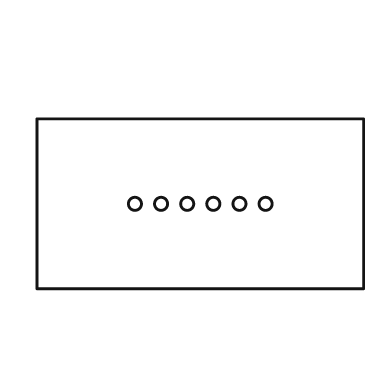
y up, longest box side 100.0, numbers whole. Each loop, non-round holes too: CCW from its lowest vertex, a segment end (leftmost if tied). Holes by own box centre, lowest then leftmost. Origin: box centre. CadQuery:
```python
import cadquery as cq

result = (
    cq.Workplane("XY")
    .moveTo(-50.0, -26.0)
    .lineTo(50.0, -26.0)
    .lineTo(50.0, 26.0)
    .lineTo(-50.0, 26.0)
    .close()
    .moveTo(-20.0, 0.0)
    .circle(2.0)
    .moveTo(-12.0, 0.0)
    .circle(2.0)
    .moveTo(-4.0, 0.0)
    .circle(2.0)
    .moveTo(4.0, 0.0)
    .circle(2.0)
    .moveTo(12.0, 0.0)
    .circle(2.0)
    .moveTo(20.0, 0.0)
    .circle(2.0)
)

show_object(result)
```